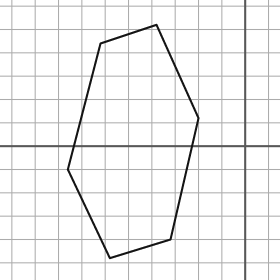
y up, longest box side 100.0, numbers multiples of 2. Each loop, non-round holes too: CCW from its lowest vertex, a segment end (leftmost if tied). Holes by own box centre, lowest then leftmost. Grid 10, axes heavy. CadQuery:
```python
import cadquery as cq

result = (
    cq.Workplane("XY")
    .moveTo(-58.0, -48.0)
    .lineTo(-32.0, -40.0)
    .lineTo(-20.0, 12.0)
    .lineTo(-38.0, 52.0)
    .lineTo(-62.0, 44.0)
    .lineTo(-76.0, -10.0)
    .close()
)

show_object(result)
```